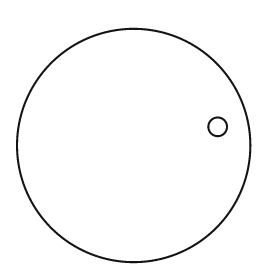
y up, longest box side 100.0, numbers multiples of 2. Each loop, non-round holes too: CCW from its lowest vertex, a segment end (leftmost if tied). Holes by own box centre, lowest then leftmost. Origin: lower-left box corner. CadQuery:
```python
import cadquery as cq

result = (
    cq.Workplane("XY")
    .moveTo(50.0, 50.0)
    .circle(50.0)
    .moveTo(86.0, 58.0)
    .circle(4.0)
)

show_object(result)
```